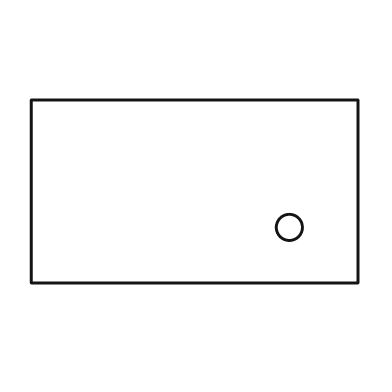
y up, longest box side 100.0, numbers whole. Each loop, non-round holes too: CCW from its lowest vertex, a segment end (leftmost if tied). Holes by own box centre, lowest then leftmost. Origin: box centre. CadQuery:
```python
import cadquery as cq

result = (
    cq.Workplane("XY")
    .moveTo(-50.0, -28.0)
    .lineTo(50.0, -28.0)
    .lineTo(50.0, 28.0)
    .lineTo(-50.0, 28.0)
    .close()
    .moveTo(29.0, -11.0)
    .circle(4.0)
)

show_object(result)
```